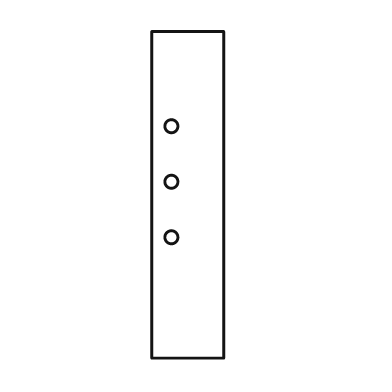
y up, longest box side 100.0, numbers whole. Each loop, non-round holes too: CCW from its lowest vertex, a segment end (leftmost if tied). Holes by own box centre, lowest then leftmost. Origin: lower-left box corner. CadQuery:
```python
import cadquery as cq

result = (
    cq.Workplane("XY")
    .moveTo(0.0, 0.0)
    .lineTo(22.0, 0.0)
    .lineTo(22.0, 100.0)
    .lineTo(0.0, 100.0)
    .close()
    .moveTo(6.0, 37.0)
    .circle(2.0)
    .moveTo(6.0, 54.0)
    .circle(2.0)
    .moveTo(6.0, 71.0)
    .circle(2.0)
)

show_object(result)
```